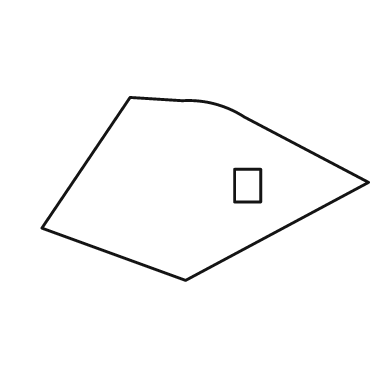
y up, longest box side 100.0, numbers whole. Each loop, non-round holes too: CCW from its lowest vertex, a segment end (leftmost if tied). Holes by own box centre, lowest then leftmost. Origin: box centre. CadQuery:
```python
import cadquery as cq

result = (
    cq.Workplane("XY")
    .moveTo(-6.0, -28.0)
    .lineTo(50.0, 2.0)
    .lineTo(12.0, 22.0)
    .threePointArc((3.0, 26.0), (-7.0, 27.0))
    .lineTo(-23.0, 28.0)
    .lineTo(-50.0, -12.0)
    .close()
    .moveTo(9.0, -4.0)
    .lineTo(17.0, -4.0)
    .lineTo(17.0, 6.0)
    .lineTo(9.0, 6.0)
    .close()
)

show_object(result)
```